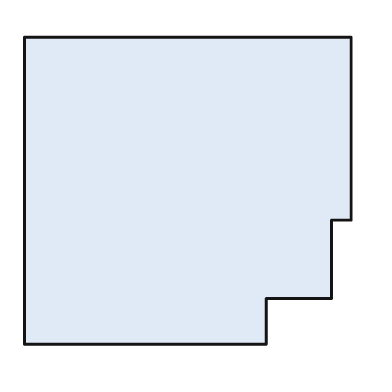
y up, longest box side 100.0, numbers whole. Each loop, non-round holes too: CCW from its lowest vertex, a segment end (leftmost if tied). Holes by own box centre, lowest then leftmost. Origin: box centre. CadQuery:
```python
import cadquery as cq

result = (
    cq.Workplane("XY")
    .moveTo(-50.0, -47.0)
    .lineTo(24.0, -47.0)
    .lineTo(24.0, -33.0)
    .lineTo(44.0, -33.0)
    .lineTo(44.0, -9.0)
    .lineTo(50.0, -9.0)
    .lineTo(50.0, 47.0)
    .lineTo(-50.0, 47.0)
    .close()
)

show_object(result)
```